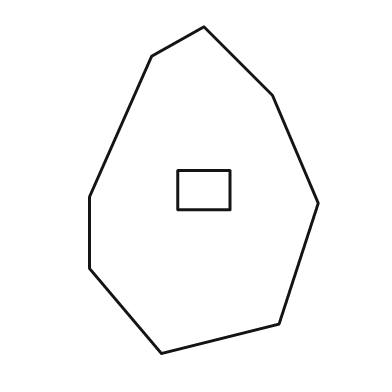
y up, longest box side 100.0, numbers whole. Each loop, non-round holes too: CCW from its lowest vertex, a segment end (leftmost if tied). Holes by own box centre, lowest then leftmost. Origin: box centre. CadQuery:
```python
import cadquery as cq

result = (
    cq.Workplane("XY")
    .moveTo(-13.0, -50.0)
    .lineTo(23.0, -41.0)
    .lineTo(35.0, -4.0)
    .lineTo(21.0, 29.0)
    .lineTo(0.0, 50.0)
    .lineTo(-16.0, 41.0)
    .lineTo(-35.0, -2.0)
    .lineTo(-35.0, -24.0)
    .close()
    .moveTo(-8.0, -6.0)
    .lineTo(8.0, -6.0)
    .lineTo(8.0, 6.0)
    .lineTo(-8.0, 6.0)
    .close()
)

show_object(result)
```